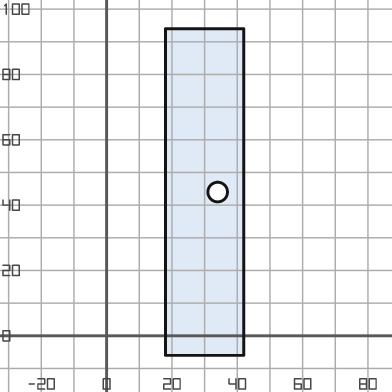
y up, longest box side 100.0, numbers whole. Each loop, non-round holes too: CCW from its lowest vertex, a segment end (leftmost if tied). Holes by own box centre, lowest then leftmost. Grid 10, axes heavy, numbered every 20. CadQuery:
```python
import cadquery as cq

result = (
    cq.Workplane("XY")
    .moveTo(18.0, -6.0)
    .lineTo(42.0, -6.0)
    .lineTo(42.0, 94.0)
    .lineTo(18.0, 94.0)
    .close()
    .moveTo(34.0, 44.0)
    .circle(3.0)
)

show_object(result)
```